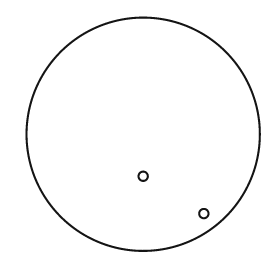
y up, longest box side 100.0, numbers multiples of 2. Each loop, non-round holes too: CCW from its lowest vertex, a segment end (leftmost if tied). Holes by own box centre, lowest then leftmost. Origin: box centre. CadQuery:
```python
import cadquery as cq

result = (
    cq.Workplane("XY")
    .moveTo(0.0, 0.0)
    .circle(50.0)
    .moveTo(26.0, -34.0)
    .circle(2.0)
    .moveTo(0.0, -18.0)
    .circle(2.0)
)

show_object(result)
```